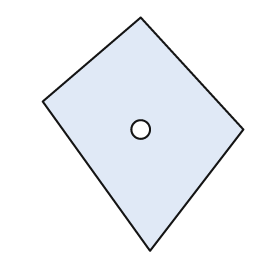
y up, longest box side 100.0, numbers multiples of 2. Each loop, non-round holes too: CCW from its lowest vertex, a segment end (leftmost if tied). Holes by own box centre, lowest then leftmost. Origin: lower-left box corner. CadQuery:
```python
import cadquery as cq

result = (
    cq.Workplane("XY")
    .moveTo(46.0, 0.0)
    .lineTo(86.0, 52.0)
    .lineTo(42.0, 100.0)
    .lineTo(0.0, 64.0)
    .close()
    .moveTo(42.0, 52.0)
    .circle(4.0)
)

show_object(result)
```